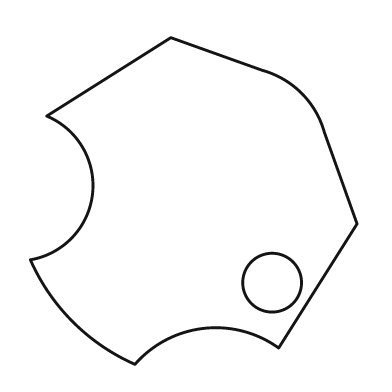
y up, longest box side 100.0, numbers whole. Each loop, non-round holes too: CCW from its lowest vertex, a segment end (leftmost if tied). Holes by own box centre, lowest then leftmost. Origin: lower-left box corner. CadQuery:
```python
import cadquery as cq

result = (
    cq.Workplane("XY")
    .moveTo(32.0, 0.0)
    .threePointArc((53.0, 11.0), (76.0, 5.0))
    .lineTo(100.0, 43.0)
    .lineTo(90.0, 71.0)
    .threePointArc((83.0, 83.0), (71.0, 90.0))
    .lineTo(43.0, 100.0)
    .lineTo(5.0, 76.0)
    .threePointArc((19.0, 52.0), (0.0, 32.0))
    .threePointArc((13.0, 13.0), (32.0, 0.0))
    .close()
    .moveTo(74.0, 25.0)
    .circle(9.0)
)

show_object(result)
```